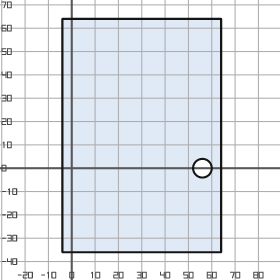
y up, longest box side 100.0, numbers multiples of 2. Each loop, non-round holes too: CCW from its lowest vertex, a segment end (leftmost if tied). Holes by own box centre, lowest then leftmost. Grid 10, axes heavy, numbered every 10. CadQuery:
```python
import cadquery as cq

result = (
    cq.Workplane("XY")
    .moveTo(-4.0, -36.0)
    .lineTo(64.0, -36.0)
    .lineTo(64.0, 64.0)
    .lineTo(-4.0, 64.0)
    .close()
    .moveTo(56.0, 0.0)
    .circle(4.0)
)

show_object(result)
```